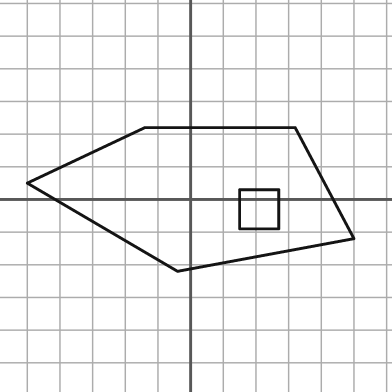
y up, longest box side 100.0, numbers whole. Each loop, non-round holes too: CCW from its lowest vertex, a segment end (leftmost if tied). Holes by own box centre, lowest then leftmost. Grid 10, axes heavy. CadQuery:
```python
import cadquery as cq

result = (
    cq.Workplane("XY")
    .moveTo(-4.0, -22.0)
    .lineTo(50.0, -12.0)
    .lineTo(32.0, 22.0)
    .lineTo(-14.0, 22.0)
    .lineTo(-50.0, 5.0)
    .close()
    .moveTo(15.0, -9.0)
    .lineTo(27.0, -9.0)
    .lineTo(27.0, 3.0)
    .lineTo(15.0, 3.0)
    .close()
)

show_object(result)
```